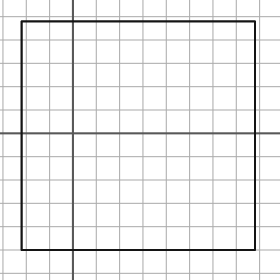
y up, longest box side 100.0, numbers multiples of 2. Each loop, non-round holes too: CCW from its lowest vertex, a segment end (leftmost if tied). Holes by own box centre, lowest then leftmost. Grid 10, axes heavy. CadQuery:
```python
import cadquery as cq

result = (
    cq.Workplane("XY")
    .moveTo(-22.0, -50.0)
    .lineTo(78.0, -50.0)
    .lineTo(78.0, 48.0)
    .lineTo(-22.0, 48.0)
    .close()
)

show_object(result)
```